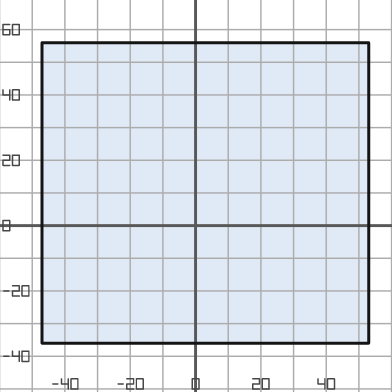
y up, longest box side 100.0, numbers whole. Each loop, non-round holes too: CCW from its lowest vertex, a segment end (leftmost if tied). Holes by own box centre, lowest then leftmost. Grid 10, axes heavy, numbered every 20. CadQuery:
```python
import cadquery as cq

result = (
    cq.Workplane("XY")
    .moveTo(-47.0, -36.0)
    .lineTo(53.0, -36.0)
    .lineTo(53.0, 56.0)
    .lineTo(-47.0, 56.0)
    .close()
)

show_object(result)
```